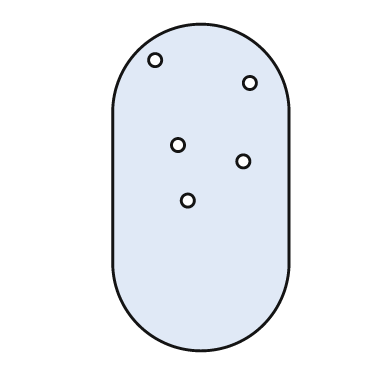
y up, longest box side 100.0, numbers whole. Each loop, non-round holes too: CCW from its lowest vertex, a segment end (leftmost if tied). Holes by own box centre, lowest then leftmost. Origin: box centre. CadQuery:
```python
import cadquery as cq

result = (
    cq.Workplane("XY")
    .moveTo(-27.0, -23.0)
    .threePointArc((0.0, -50.0), (27.0, -23.0))
    .lineTo(27.0, 23.0)
    .threePointArc((0.0, 50.0), (-27.0, 23.0))
    .close()
    .moveTo(-4.0, -4.0)
    .circle(2.0)
    .moveTo(13.0, 8.0)
    .circle(2.0)
    .moveTo(-7.0, 13.0)
    .circle(2.0)
    .moveTo(15.0, 32.0)
    .circle(2.0)
    .moveTo(-14.0, 39.0)
    .circle(2.0)
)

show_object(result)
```